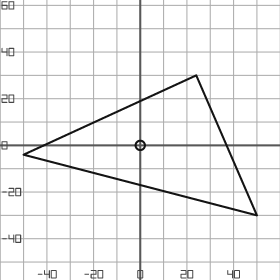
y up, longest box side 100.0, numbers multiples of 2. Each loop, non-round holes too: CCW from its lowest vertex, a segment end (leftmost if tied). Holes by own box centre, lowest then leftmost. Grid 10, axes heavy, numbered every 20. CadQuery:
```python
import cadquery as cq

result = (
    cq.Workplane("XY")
    .moveTo(50.0, -30.0)
    .lineTo(24.0, 30.0)
    .lineTo(-50.0, -4.0)
    .close()
    .moveTo(0.0, 0.0)
    .circle(2.0)
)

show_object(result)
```